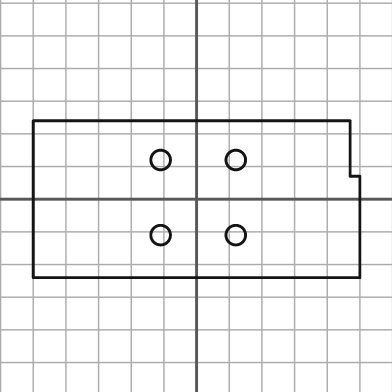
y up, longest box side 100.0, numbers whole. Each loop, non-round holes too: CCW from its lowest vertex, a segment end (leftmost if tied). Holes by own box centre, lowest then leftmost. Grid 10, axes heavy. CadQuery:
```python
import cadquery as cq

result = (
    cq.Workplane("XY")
    .moveTo(-50.0, -24.0)
    .lineTo(50.0, -24.0)
    .lineTo(50.0, 7.0)
    .lineTo(47.0, 7.0)
    .lineTo(47.0, 24.0)
    .lineTo(-50.0, 24.0)
    .close()
    .moveTo(-11.0, -11.0)
    .circle(3.0)
    .moveTo(12.0, -11.0)
    .circle(3.0)
    .moveTo(-11.0, 12.0)
    .circle(3.0)
    .moveTo(12.0, 12.0)
    .circle(3.0)
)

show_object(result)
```